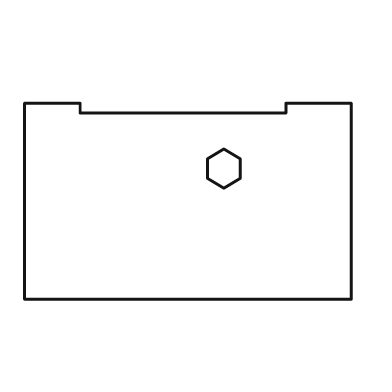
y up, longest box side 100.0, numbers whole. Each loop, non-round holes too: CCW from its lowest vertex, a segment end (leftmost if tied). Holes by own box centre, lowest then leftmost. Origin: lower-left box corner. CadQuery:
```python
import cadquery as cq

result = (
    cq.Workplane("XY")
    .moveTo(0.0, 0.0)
    .lineTo(100.0, 0.0)
    .lineTo(100.0, 60.0)
    .lineTo(80.0, 60.0)
    .lineTo(80.0, 57.0)
    .lineTo(17.0, 57.0)
    .lineTo(17.0, 60.0)
    .lineTo(0.0, 60.0)
    .close()
    .moveTo(61.0, 34.0)
    .lineTo(66.0, 37.0)
    .lineTo(66.0, 43.0)
    .lineTo(61.0, 46.0)
    .lineTo(56.0, 43.0)
    .lineTo(56.0, 37.0)
    .close()
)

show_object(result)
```